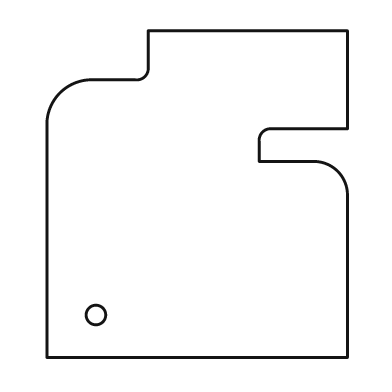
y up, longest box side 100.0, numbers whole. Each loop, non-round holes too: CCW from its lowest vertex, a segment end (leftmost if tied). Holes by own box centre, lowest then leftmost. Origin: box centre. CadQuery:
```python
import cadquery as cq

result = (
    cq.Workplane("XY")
    .moveTo(-46.0, -50.0)
    .lineTo(46.0, -50.0)
    .lineTo(46.0, 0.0)
    .threePointArc((43.0, 7.0), (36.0, 10.0))
    .lineTo(19.0, 10.0)
    .lineTo(19.0, 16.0)
    .threePointArc((20.0, 19.0), (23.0, 20.0))
    .lineTo(46.0, 20.0)
    .lineTo(46.0, 50.0)
    .lineTo(-15.0, 50.0)
    .lineTo(-15.0, 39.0)
    .threePointArc((-16.0, 36.0), (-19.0, 35.0))
    .lineTo(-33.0, 35.0)
    .threePointArc((-42.0, 31.0), (-46.0, 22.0))
    .close()
    .moveTo(-31.0, -37.0)
    .circle(3.0)
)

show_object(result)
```